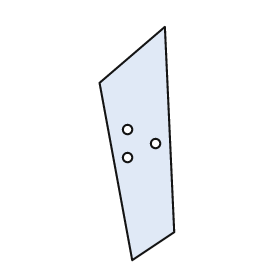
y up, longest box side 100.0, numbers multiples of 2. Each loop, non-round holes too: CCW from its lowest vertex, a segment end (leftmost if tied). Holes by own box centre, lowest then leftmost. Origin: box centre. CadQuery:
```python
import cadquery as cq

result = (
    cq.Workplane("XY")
    .moveTo(-2.0, -50.0)
    .lineTo(16.0, -38.0)
    .lineTo(12.0, 50.0)
    .lineTo(-16.0, 26.0)
    .close()
    .moveTo(-4.0, -6.0)
    .circle(2.0)
    .moveTo(8.0, 0.0)
    .circle(2.0)
    .moveTo(-4.0, 6.0)
    .circle(2.0)
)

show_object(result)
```